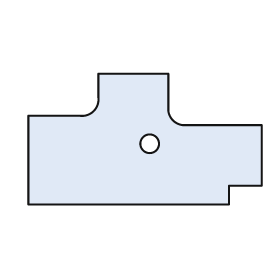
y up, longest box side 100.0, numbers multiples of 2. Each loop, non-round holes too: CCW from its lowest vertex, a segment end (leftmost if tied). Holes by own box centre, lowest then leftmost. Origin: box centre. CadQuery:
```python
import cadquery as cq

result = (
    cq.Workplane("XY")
    .moveTo(-50.0, -28.0)
    .lineTo(36.0, -28.0)
    .lineTo(36.0, -20.0)
    .lineTo(50.0, -20.0)
    .lineTo(50.0, 6.0)
    .lineTo(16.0, 6.0)
    .threePointArc((12.0, 8.0), (10.0, 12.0))
    .lineTo(10.0, 28.0)
    .lineTo(-20.0, 28.0)
    .lineTo(-20.0, 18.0)
    .threePointArc((-22.0, 12.0), (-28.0, 10.0))
    .lineTo(-50.0, 10.0)
    .close()
    .moveTo(2.0, -2.0)
    .circle(4.0)
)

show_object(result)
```